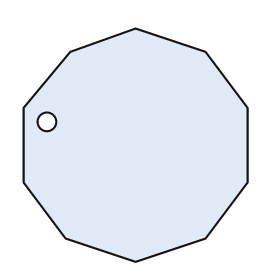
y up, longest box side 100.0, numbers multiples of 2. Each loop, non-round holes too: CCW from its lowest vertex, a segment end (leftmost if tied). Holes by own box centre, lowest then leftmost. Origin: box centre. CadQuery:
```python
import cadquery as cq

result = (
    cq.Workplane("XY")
    .moveTo(0.0, -50.0)
    .lineTo(30.0, -40.0)
    .lineTo(48.0, -16.0)
    .lineTo(48.0, 16.0)
    .lineTo(30.0, 40.0)
    .lineTo(0.0, 50.0)
    .lineTo(-28.0, 40.0)
    .lineTo(-48.0, 16.0)
    .lineTo(-48.0, -16.0)
    .lineTo(-30.0, -40.0)
    .close()
    .moveTo(-38.0, 10.0)
    .circle(4.0)
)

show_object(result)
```